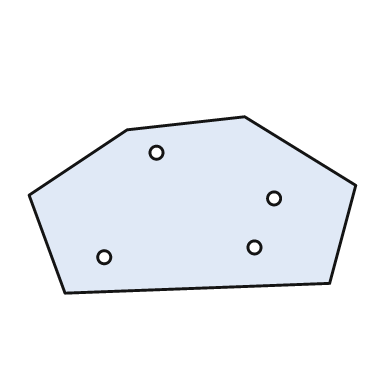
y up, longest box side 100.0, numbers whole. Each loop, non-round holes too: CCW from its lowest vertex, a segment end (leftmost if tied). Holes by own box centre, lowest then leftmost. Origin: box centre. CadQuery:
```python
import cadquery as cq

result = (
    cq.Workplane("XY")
    .moveTo(-39.0, -27.0)
    .lineTo(42.0, -24.0)
    .lineTo(50.0, 6.0)
    .lineTo(16.0, 27.0)
    .lineTo(-20.0, 23.0)
    .lineTo(-50.0, 3.0)
    .close()
    .moveTo(-27.0, -16.0)
    .circle(2.0)
    .moveTo(19.0, -13.0)
    .circle(2.0)
    .moveTo(25.0, 2.0)
    .circle(2.0)
    .moveTo(-11.0, 16.0)
    .circle(2.0)
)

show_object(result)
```